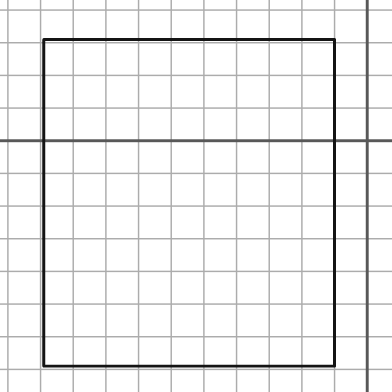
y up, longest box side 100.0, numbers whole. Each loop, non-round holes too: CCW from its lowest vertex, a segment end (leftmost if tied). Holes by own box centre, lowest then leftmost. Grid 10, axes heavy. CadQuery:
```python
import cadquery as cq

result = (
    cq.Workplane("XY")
    .moveTo(-99.0, -69.0)
    .lineTo(-10.0, -69.0)
    .lineTo(-10.0, 31.0)
    .lineTo(-99.0, 31.0)
    .close()
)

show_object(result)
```